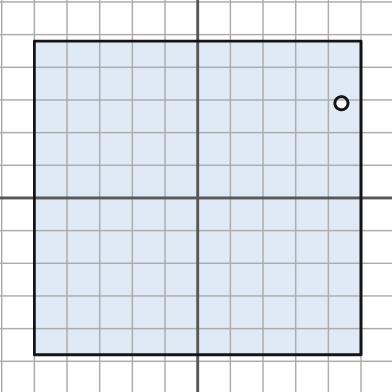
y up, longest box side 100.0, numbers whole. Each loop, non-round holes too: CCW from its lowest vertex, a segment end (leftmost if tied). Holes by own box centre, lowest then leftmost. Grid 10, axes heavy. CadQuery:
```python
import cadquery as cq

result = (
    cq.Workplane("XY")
    .moveTo(-50.0, -48.0)
    .lineTo(50.0, -48.0)
    .lineTo(50.0, 48.0)
    .lineTo(-50.0, 48.0)
    .close()
    .moveTo(44.0, 29.0)
    .circle(2.0)
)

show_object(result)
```